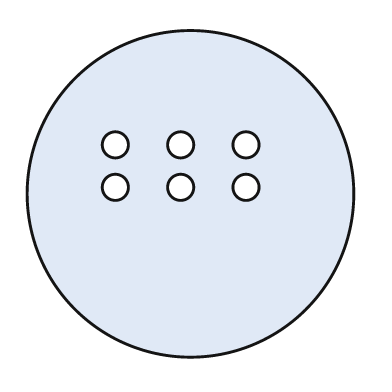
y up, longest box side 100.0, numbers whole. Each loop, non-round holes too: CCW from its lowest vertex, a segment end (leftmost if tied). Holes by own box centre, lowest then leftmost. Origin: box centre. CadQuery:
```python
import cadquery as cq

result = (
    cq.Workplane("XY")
    .moveTo(0.0, 0.0)
    .circle(50.0)
    .moveTo(-23.0, 2.0)
    .circle(4.0)
    .moveTo(-3.0, 2.0)
    .circle(4.0)
    .moveTo(17.0, 2.0)
    .circle(4.0)
    .moveTo(-23.0, 15.0)
    .circle(4.0)
    .moveTo(-3.0, 15.0)
    .circle(4.0)
    .moveTo(17.0, 15.0)
    .circle(4.0)
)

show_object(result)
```